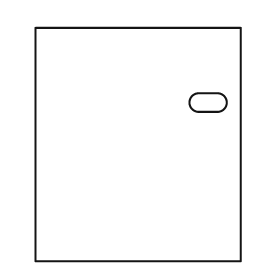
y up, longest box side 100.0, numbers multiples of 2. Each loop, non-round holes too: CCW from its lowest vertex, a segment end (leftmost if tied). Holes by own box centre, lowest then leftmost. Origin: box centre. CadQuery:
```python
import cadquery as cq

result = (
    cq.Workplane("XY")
    .moveTo(-44.0, -50.0)
    .lineTo(44.0, -50.0)
    .lineTo(44.0, 50.0)
    .lineTo(-44.0, 50.0)
    .close()
    .moveTo(26.0, 14.0)
    .lineTo(34.0, 14.0)
    .threePointArc((38.0, 18.0), (34.0, 22.0))
    .lineTo(26.0, 22.0)
    .threePointArc((22.0, 18.0), (26.0, 14.0))
    .close()
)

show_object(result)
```